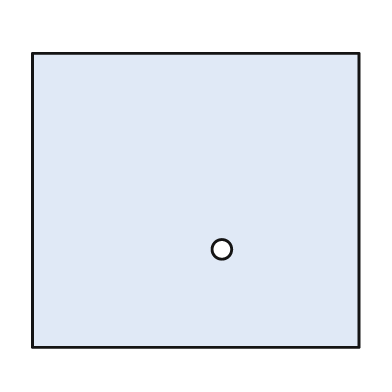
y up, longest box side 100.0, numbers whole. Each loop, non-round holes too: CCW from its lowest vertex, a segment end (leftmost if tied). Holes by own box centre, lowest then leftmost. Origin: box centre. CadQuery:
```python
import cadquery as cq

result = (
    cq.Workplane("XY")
    .moveTo(-50.0, -45.0)
    .lineTo(50.0, -45.0)
    .lineTo(50.0, 45.0)
    .lineTo(-50.0, 45.0)
    .close()
    .moveTo(8.0, -15.0)
    .circle(3.0)
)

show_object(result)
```